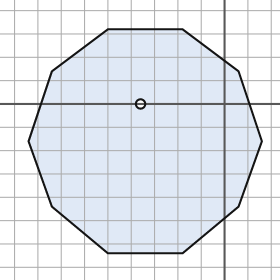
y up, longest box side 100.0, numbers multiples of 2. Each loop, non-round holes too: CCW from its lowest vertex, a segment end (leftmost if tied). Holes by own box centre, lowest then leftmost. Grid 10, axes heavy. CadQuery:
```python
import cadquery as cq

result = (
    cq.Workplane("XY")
    .moveTo(-50.0, -64.0)
    .lineTo(-18.0, -64.0)
    .lineTo(6.0, -44.0)
    .lineTo(16.0, -16.0)
    .lineTo(6.0, 14.0)
    .lineTo(-18.0, 32.0)
    .lineTo(-50.0, 32.0)
    .lineTo(-74.0, 14.0)
    .lineTo(-84.0, -16.0)
    .lineTo(-74.0, -44.0)
    .close()
    .moveTo(-36.0, 0.0)
    .circle(2.0)
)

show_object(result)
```